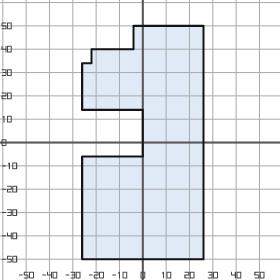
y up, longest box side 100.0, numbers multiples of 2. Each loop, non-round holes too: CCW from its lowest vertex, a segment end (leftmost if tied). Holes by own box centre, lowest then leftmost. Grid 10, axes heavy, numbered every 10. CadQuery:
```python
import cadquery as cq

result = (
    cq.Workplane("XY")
    .moveTo(-26.0, -50.0)
    .lineTo(26.0, -50.0)
    .lineTo(26.0, 50.0)
    .lineTo(-4.0, 50.0)
    .lineTo(-4.0, 40.0)
    .lineTo(-22.0, 40.0)
    .lineTo(-22.0, 34.0)
    .lineTo(-26.0, 34.0)
    .lineTo(-26.0, 14.0)
    .lineTo(0.0, 14.0)
    .lineTo(0.0, -6.0)
    .lineTo(-26.0, -6.0)
    .close()
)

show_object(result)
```